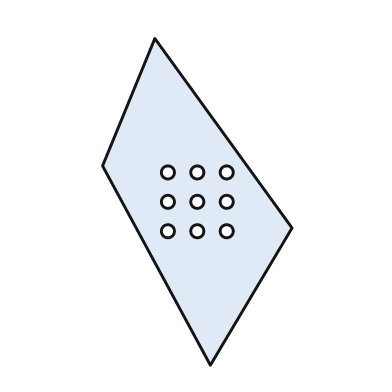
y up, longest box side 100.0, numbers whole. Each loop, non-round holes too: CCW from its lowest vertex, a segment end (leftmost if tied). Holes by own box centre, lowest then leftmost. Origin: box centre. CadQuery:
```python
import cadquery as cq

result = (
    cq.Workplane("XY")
    .moveTo(4.0, -50.0)
    .lineTo(29.0, -8.0)
    .lineTo(-13.0, 50.0)
    .lineTo(-29.0, 11.0)
    .close()
    .moveTo(-9.0, -9.0)
    .circle(2.0)
    .moveTo(0.0, -9.0)
    .circle(2.0)
    .moveTo(9.0, -9.0)
    .circle(2.0)
    .moveTo(-9.0, 0.0)
    .circle(2.0)
    .moveTo(0.0, 0.0)
    .circle(2.0)
    .moveTo(9.0, 0.0)
    .circle(2.0)
    .moveTo(-9.0, 9.0)
    .circle(2.0)
    .moveTo(0.0, 9.0)
    .circle(2.0)
    .moveTo(9.0, 9.0)
    .circle(2.0)
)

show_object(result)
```